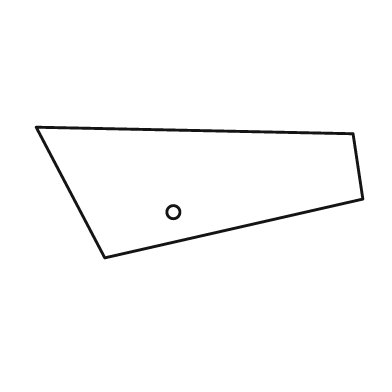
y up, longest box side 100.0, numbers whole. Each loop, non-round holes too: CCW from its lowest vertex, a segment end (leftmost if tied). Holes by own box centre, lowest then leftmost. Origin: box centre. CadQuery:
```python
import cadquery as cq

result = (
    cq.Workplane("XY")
    .moveTo(-29.0, -20.0)
    .lineTo(50.0, -2.0)
    .lineTo(47.0, 18.0)
    .lineTo(-50.0, 20.0)
    .close()
    .moveTo(-8.0, -6.0)
    .circle(2.0)
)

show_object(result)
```